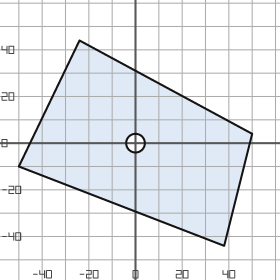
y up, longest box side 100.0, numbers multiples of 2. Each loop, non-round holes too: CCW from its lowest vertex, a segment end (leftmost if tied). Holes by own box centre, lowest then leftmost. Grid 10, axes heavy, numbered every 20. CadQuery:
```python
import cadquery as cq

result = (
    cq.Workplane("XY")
    .moveTo(38.0, -44.0)
    .lineTo(50.0, 4.0)
    .lineTo(-24.0, 44.0)
    .lineTo(-50.0, -10.0)
    .close()
    .moveTo(0.0, 0.0)
    .circle(4.0)
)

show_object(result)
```